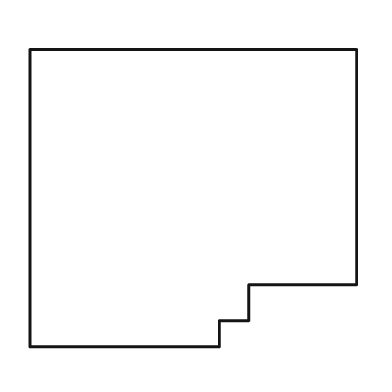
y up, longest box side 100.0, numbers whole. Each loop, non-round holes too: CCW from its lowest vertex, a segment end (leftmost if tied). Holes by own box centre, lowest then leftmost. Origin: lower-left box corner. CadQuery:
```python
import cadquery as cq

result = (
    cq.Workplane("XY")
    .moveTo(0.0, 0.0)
    .lineTo(58.0, 0.0)
    .lineTo(58.0, 8.0)
    .lineTo(67.0, 8.0)
    .lineTo(67.0, 19.0)
    .lineTo(100.0, 19.0)
    .lineTo(100.0, 91.0)
    .lineTo(0.0, 91.0)
    .close()
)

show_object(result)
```